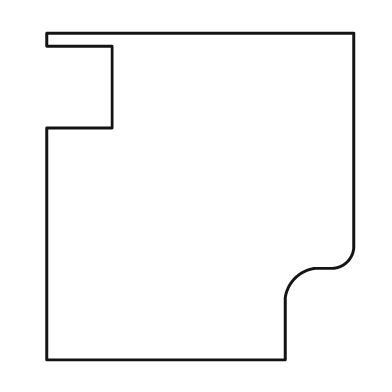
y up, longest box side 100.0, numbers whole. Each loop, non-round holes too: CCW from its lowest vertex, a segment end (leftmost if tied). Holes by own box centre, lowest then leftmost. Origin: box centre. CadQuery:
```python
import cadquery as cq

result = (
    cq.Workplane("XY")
    .moveTo(-47.0, -50.0)
    .lineTo(26.0, -50.0)
    .lineTo(26.0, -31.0)
    .threePointArc((29.0, -25.0), (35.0, -22.0))
    .lineTo(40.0, -22.0)
    .threePointArc((45.0, -20.0), (47.0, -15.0))
    .lineTo(47.0, 50.0)
    .lineTo(-47.0, 50.0)
    .lineTo(-47.0, 46.0)
    .lineTo(-27.0, 46.0)
    .lineTo(-27.0, 21.0)
    .lineTo(-47.0, 21.0)
    .close()
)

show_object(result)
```